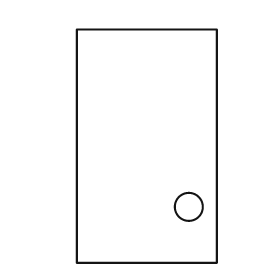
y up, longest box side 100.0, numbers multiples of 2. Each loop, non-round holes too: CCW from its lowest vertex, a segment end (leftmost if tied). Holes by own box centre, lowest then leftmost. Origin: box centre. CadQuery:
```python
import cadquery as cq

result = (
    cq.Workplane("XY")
    .moveTo(-30.0, -50.0)
    .lineTo(30.0, -50.0)
    .lineTo(30.0, 50.0)
    .lineTo(-30.0, 50.0)
    .close()
    .moveTo(18.0, -26.0)
    .circle(6.0)
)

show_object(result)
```